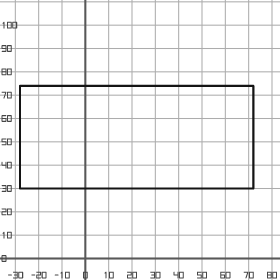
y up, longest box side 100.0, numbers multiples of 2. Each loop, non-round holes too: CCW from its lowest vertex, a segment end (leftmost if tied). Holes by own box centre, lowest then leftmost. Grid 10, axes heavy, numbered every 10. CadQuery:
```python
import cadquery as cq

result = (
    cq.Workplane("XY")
    .moveTo(-28.0, 30.0)
    .lineTo(72.0, 30.0)
    .lineTo(72.0, 74.0)
    .lineTo(-28.0, 74.0)
    .close()
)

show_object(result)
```